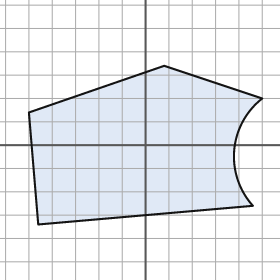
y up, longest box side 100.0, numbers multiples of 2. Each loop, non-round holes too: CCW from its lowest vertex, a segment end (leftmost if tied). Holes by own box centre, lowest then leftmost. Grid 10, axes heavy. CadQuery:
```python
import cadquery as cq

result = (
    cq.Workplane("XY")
    .moveTo(-46.0, -34.0)
    .lineTo(46.0, -26.0)
    .threePointArc((38.0, -2.0), (50.0, 20.0))
    .lineTo(8.0, 34.0)
    .lineTo(-50.0, 14.0)
    .close()
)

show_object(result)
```